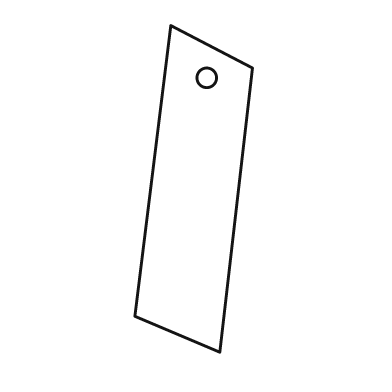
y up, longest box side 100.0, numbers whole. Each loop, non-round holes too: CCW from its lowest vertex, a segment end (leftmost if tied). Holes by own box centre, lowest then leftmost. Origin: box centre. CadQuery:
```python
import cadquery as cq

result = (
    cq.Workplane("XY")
    .moveTo(8.0, -50.0)
    .lineTo(18.0, 37.0)
    .lineTo(-7.0, 50.0)
    .lineTo(-18.0, -39.0)
    .close()
    .moveTo(4.0, 34.0)
    .circle(3.0)
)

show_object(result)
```